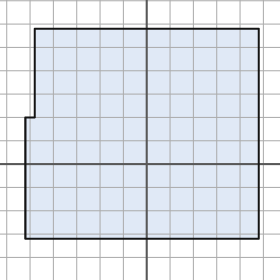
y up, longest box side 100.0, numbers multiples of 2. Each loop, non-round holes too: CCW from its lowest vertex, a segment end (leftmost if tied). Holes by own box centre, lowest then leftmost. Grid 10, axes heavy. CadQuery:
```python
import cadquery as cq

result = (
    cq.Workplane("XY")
    .moveTo(-52.0, -32.0)
    .lineTo(48.0, -32.0)
    .lineTo(48.0, 58.0)
    .lineTo(-48.0, 58.0)
    .lineTo(-48.0, 20.0)
    .lineTo(-52.0, 20.0)
    .close()
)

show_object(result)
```